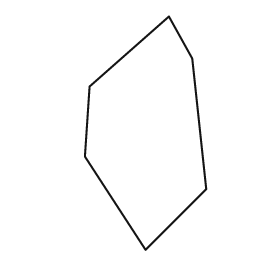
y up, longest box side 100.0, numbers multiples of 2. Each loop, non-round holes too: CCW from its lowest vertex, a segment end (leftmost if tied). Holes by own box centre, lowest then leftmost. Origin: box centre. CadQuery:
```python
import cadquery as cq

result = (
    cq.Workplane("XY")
    .moveTo(0.0, -50.0)
    .lineTo(26.0, -24.0)
    .lineTo(20.0, 32.0)
    .lineTo(10.0, 50.0)
    .lineTo(-24.0, 20.0)
    .lineTo(-26.0, -10.0)
    .close()
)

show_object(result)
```